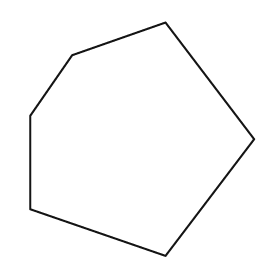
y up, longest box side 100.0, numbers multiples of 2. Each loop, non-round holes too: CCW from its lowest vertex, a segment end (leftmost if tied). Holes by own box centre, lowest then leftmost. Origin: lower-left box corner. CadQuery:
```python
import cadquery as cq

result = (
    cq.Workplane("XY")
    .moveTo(58.0, 0.0)
    .lineTo(96.0, 50.0)
    .lineTo(58.0, 100.0)
    .lineTo(18.0, 86.0)
    .lineTo(0.0, 60.0)
    .lineTo(0.0, 20.0)
    .close()
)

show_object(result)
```